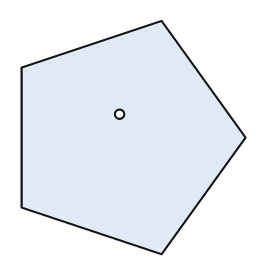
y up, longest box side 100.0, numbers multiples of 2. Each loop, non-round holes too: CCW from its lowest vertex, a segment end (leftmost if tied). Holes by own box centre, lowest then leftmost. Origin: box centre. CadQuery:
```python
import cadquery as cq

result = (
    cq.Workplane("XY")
    .moveTo(12.0, -50.0)
    .lineTo(48.0, 0.0)
    .lineTo(12.0, 50.0)
    .lineTo(-48.0, 30.0)
    .lineTo(-48.0, -30.0)
    .close()
    .moveTo(-6.0, 10.0)
    .circle(2.0)
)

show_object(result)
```